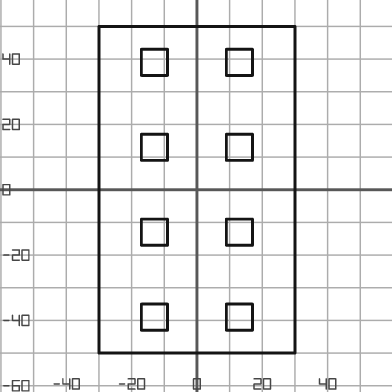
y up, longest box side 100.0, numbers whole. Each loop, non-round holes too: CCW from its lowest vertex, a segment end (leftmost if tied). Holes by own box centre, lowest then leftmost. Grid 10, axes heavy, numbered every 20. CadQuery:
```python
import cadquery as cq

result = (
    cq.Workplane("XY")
    .moveTo(-30.0, -50.0)
    .lineTo(30.0, -50.0)
    .lineTo(30.0, 50.0)
    .lineTo(-30.0, 50.0)
    .close()
    .moveTo(-17.0, -43.0)
    .lineTo(-9.0, -43.0)
    .lineTo(-9.0, -35.0)
    .lineTo(-17.0, -35.0)
    .close()
    .moveTo(9.0, -43.0)
    .lineTo(17.0, -43.0)
    .lineTo(17.0, -35.0)
    .lineTo(9.0, -35.0)
    .close()
    .moveTo(-17.0, -17.0)
    .lineTo(-9.0, -17.0)
    .lineTo(-9.0, -9.0)
    .lineTo(-17.0, -9.0)
    .close()
    .moveTo(9.0, -17.0)
    .lineTo(17.0, -17.0)
    .lineTo(17.0, -9.0)
    .lineTo(9.0, -9.0)
    .close()
    .moveTo(-17.0, 9.0)
    .lineTo(-9.0, 9.0)
    .lineTo(-9.0, 17.0)
    .lineTo(-17.0, 17.0)
    .close()
    .moveTo(9.0, 9.0)
    .lineTo(17.0, 9.0)
    .lineTo(17.0, 17.0)
    .lineTo(9.0, 17.0)
    .close()
    .moveTo(-17.0, 35.0)
    .lineTo(-9.0, 35.0)
    .lineTo(-9.0, 43.0)
    .lineTo(-17.0, 43.0)
    .close()
    .moveTo(9.0, 35.0)
    .lineTo(17.0, 35.0)
    .lineTo(17.0, 43.0)
    .lineTo(9.0, 43.0)
    .close()
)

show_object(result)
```